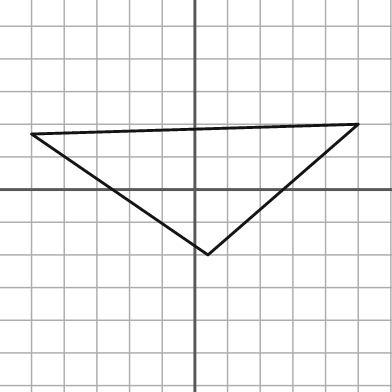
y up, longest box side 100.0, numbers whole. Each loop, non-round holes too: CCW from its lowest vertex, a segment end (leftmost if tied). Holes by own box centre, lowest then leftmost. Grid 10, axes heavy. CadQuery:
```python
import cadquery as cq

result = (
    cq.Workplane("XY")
    .moveTo(4.0, -20.0)
    .lineTo(50.0, 20.0)
    .lineTo(-50.0, 17.0)
    .close()
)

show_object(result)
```